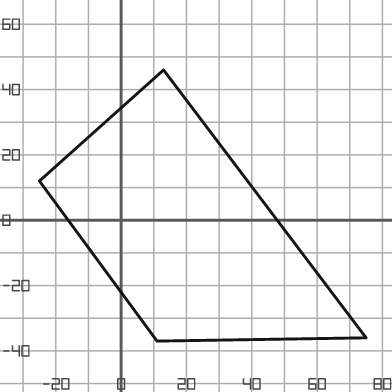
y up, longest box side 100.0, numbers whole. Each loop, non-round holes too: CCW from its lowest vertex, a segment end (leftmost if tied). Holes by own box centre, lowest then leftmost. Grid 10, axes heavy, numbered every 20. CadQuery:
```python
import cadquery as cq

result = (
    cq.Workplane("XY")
    .moveTo(11.0, -37.0)
    .lineTo(75.0, -36.0)
    .lineTo(13.0, 46.0)
    .lineTo(-25.0, 12.0)
    .close()
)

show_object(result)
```